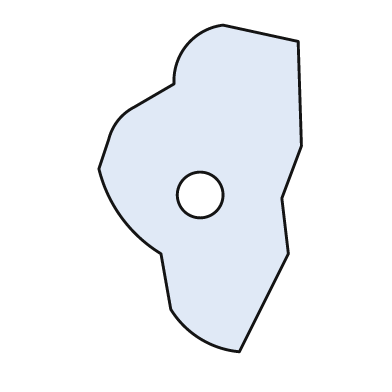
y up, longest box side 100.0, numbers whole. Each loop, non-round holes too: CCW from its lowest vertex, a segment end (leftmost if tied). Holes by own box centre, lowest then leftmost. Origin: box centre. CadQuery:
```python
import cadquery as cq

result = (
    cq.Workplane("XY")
    .moveTo(12.0, -50.0)
    .lineTo(27.0, -20.0)
    .lineTo(25.0, -3.0)
    .lineTo(31.0, 13.0)
    .lineTo(30.0, 45.0)
    .lineTo(7.0, 50.0)
    .threePointArc((-4.0, 44.0), (-8.0, 32.0))
    .lineTo(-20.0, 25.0)
    .threePointArc((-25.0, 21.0), (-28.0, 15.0))
    .lineTo(-31.0, 6.0)
    .threePointArc((-24.0, -9.0), (-12.0, -20.0))
    .lineTo(-9.0, -37.0)
    .threePointArc((0.0, -46.0), (12.0, -50.0))
    .close()
    .moveTo(0.0, -2.0)
    .circle(7.0)
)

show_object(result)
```